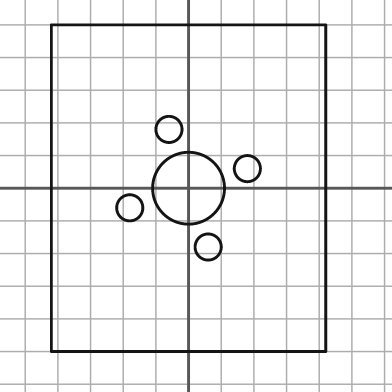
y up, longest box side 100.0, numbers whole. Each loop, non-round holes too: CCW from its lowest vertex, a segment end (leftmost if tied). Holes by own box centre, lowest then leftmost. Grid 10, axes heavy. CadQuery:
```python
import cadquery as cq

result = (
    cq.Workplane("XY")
    .moveTo(-42.0, -50.0)
    .lineTo(42.0, -50.0)
    .lineTo(42.0, 50.0)
    .lineTo(-42.0, 50.0)
    .close()
    .moveTo(6.0, -18.0)
    .circle(4.0)
    .moveTo(-18.0, -6.0)
    .circle(4.0)
    .moveTo(0.0, 0.0)
    .circle(11.0)
    .moveTo(18.0, 6.0)
    .circle(4.0)
    .moveTo(-6.0, 18.0)
    .circle(4.0)
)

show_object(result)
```